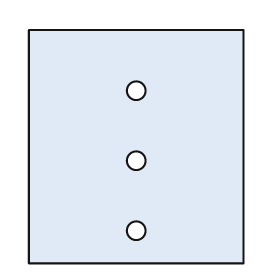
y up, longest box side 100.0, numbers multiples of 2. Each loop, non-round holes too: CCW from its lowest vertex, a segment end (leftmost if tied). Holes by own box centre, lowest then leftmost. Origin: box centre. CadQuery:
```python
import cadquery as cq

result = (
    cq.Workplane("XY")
    .moveTo(-46.0, -50.0)
    .lineTo(46.0, -50.0)
    .lineTo(46.0, 50.0)
    .lineTo(-46.0, 50.0)
    .close()
    .moveTo(0.0, -36.0)
    .circle(4.0)
    .moveTo(0.0, -6.0)
    .circle(4.0)
    .moveTo(0.0, 24.0)
    .circle(4.0)
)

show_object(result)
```